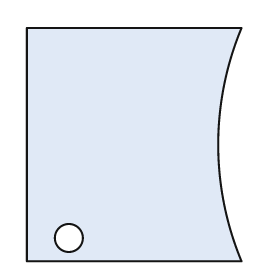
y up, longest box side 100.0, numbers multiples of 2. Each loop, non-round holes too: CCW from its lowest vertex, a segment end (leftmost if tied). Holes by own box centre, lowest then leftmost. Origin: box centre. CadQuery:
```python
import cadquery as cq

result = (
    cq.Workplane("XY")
    .moveTo(-46.0, -50.0)
    .lineTo(46.0, -50.0)
    .threePointArc((36.0, 0.0), (46.0, 50.0))
    .lineTo(-46.0, 50.0)
    .close()
    .moveTo(-28.0, -40.0)
    .circle(6.0)
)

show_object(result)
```